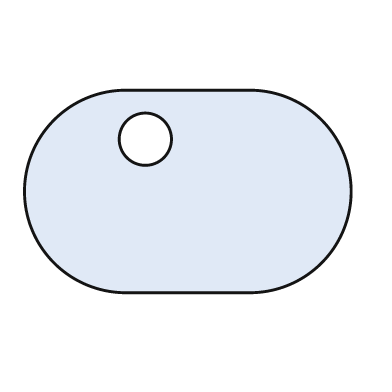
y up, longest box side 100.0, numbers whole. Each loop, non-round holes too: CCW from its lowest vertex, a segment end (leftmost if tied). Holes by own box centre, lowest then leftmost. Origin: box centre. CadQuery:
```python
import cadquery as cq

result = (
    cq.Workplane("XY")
    .moveTo(-19.0, -31.0)
    .lineTo(19.0, -31.0)
    .threePointArc((50.0, 0.0), (19.0, 31.0))
    .lineTo(-19.0, 31.0)
    .threePointArc((-50.0, 0.0), (-19.0, -31.0))
    .close()
    .moveTo(-13.0, 16.0)
    .circle(8.0)
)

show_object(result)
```